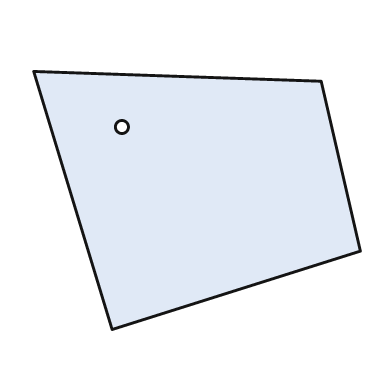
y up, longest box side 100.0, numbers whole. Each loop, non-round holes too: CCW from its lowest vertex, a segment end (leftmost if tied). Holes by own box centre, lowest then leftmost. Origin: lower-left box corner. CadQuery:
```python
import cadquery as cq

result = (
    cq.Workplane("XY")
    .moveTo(24.0, 0.0)
    .lineTo(100.0, 24.0)
    .lineTo(88.0, 76.0)
    .lineTo(0.0, 79.0)
    .close()
    .moveTo(27.0, 62.0)
    .circle(2.0)
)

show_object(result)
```